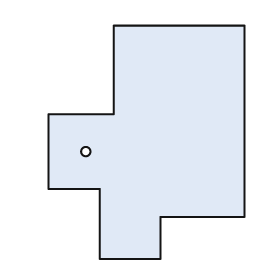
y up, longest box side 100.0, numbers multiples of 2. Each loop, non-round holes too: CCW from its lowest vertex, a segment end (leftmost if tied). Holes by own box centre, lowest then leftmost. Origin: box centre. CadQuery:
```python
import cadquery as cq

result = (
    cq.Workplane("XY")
    .moveTo(-20.0, -50.0)
    .lineTo(6.0, -50.0)
    .lineTo(6.0, -32.0)
    .lineTo(42.0, -32.0)
    .lineTo(42.0, 50.0)
    .lineTo(-14.0, 50.0)
    .lineTo(-14.0, 12.0)
    .lineTo(-42.0, 12.0)
    .lineTo(-42.0, -20.0)
    .lineTo(-20.0, -20.0)
    .close()
    .moveTo(-26.0, -4.0)
    .circle(2.0)
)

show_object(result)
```